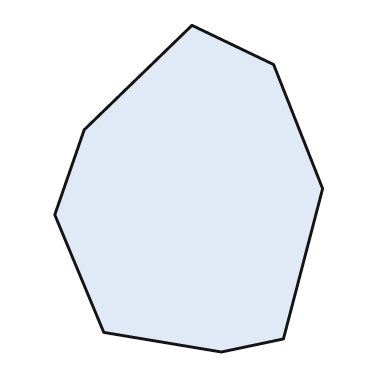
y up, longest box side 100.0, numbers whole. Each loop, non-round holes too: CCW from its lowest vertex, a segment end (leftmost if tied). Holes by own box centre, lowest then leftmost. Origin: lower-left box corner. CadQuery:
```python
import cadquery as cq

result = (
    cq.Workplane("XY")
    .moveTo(51.0, 0.0)
    .lineTo(70.0, 4.0)
    .lineTo(82.0, 50.0)
    .lineTo(67.0, 88.0)
    .lineTo(42.0, 100.0)
    .lineTo(9.0, 68.0)
    .lineTo(0.0, 42.0)
    .lineTo(15.0, 6.0)
    .close()
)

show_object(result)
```